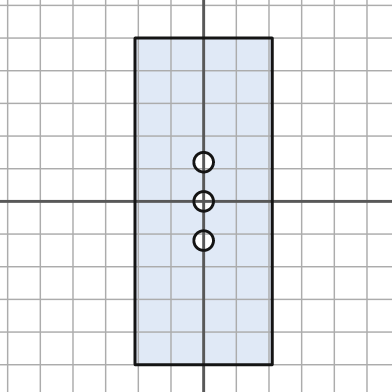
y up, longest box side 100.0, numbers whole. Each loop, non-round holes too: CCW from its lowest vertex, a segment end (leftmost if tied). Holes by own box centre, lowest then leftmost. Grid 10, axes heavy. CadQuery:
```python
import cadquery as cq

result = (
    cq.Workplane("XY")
    .moveTo(-21.0, -50.0)
    .lineTo(21.0, -50.0)
    .lineTo(21.0, 50.0)
    .lineTo(-21.0, 50.0)
    .close()
    .moveTo(0.0, -12.0)
    .circle(3.0)
    .moveTo(0.0, 0.0)
    .circle(3.0)
    .moveTo(0.0, 12.0)
    .circle(3.0)
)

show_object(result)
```